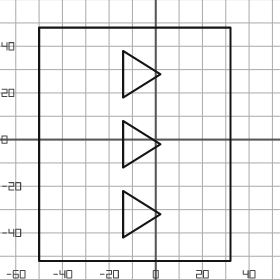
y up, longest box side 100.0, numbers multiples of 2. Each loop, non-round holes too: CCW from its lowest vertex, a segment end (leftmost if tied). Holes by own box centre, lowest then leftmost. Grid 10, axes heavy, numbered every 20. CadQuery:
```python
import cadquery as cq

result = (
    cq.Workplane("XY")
    .moveTo(-50.0, -52.0)
    .lineTo(32.0, -52.0)
    .lineTo(32.0, 48.0)
    .lineTo(-50.0, 48.0)
    .close()
    .moveTo(-14.0, -42.0)
    .lineTo(2.0, -32.0)
    .lineTo(-14.0, -22.0)
    .close()
    .moveTo(-14.0, -12.0)
    .lineTo(2.0, -2.0)
    .lineTo(-14.0, 8.0)
    .close()
    .moveTo(-14.0, 18.0)
    .lineTo(2.0, 28.0)
    .lineTo(-14.0, 38.0)
    .close()
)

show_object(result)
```